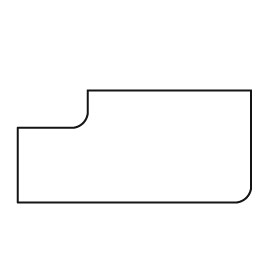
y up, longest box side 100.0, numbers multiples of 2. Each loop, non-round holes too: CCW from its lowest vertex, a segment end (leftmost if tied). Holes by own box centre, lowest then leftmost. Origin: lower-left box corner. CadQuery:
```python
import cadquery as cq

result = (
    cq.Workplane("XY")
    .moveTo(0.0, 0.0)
    .lineTo(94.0, 0.0)
    .threePointArc((98.0, 2.0), (100.0, 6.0))
    .lineTo(100.0, 48.0)
    .lineTo(30.0, 48.0)
    .lineTo(30.0, 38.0)
    .threePointArc((28.0, 34.0), (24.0, 32.0))
    .lineTo(0.0, 32.0)
    .close()
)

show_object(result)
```